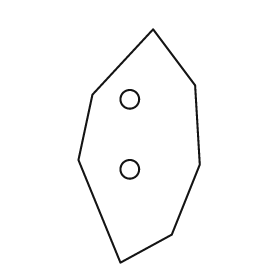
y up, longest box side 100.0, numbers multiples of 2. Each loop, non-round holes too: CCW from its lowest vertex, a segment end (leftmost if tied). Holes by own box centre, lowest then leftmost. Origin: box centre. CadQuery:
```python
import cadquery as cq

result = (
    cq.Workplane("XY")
    .moveTo(-8.0, -50.0)
    .lineTo(14.0, -38.0)
    .lineTo(26.0, -8.0)
    .lineTo(24.0, 26.0)
    .lineTo(6.0, 50.0)
    .lineTo(-20.0, 22.0)
    .lineTo(-26.0, -6.0)
    .close()
    .moveTo(-4.0, -10.0)
    .circle(4.0)
    .moveTo(-4.0, 20.0)
    .circle(4.0)
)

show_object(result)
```